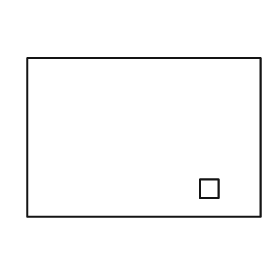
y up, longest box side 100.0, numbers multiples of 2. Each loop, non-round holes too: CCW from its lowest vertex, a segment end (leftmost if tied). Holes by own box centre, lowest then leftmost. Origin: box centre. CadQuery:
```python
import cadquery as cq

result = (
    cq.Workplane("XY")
    .moveTo(-50.0, -34.0)
    .lineTo(50.0, -34.0)
    .lineTo(50.0, 34.0)
    .lineTo(-50.0, 34.0)
    .close()
    .moveTo(24.0, -26.0)
    .lineTo(32.0, -26.0)
    .lineTo(32.0, -18.0)
    .lineTo(24.0, -18.0)
    .close()
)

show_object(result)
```